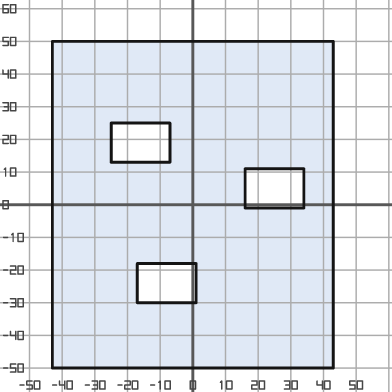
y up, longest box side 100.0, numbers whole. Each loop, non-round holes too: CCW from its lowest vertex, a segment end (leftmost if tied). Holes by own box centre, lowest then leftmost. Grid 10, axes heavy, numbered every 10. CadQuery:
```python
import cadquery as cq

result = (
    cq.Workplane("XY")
    .moveTo(-43.0, -50.0)
    .lineTo(43.0, -50.0)
    .lineTo(43.0, 50.0)
    .lineTo(-43.0, 50.0)
    .close()
    .moveTo(-17.0, -30.0)
    .lineTo(1.0, -30.0)
    .lineTo(1.0, -18.0)
    .lineTo(-17.0, -18.0)
    .close()
    .moveTo(16.0, -1.0)
    .lineTo(34.0, -1.0)
    .lineTo(34.0, 11.0)
    .lineTo(16.0, 11.0)
    .close()
    .moveTo(-25.0, 13.0)
    .lineTo(-7.0, 13.0)
    .lineTo(-7.0, 25.0)
    .lineTo(-25.0, 25.0)
    .close()
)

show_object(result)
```